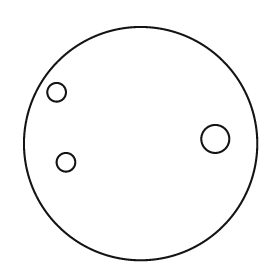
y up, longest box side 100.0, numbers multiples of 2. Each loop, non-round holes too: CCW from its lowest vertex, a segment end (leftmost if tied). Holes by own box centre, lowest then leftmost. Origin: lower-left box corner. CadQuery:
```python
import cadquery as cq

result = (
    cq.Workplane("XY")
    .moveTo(50.0, 50.0)
    .circle(50.0)
    .moveTo(18.0, 42.0)
    .circle(4.0)
    .moveTo(82.0, 52.0)
    .circle(6.0)
    .moveTo(14.0, 72.0)
    .circle(4.0)
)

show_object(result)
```